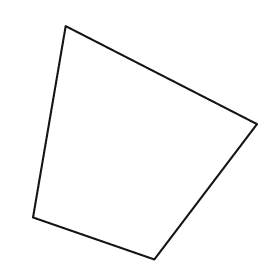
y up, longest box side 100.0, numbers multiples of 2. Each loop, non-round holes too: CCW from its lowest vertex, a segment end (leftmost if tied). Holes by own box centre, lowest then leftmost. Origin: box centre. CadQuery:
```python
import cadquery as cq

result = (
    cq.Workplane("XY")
    .moveTo(4.0, -50.0)
    .lineTo(48.0, 8.0)
    .lineTo(-34.0, 50.0)
    .lineTo(-48.0, -32.0)
    .close()
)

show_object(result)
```